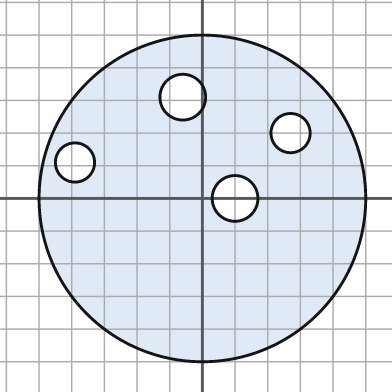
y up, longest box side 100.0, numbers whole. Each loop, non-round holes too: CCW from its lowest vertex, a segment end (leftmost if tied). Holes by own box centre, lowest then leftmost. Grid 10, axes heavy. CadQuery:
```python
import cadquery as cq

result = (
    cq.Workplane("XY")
    .moveTo(0.0, 0.0)
    .circle(50.0)
    .moveTo(10.0, 0.0)
    .circle(7.0)
    .moveTo(-39.0, 11.0)
    .circle(6.0)
    .moveTo(27.0, 20.0)
    .circle(6.0)
    .moveTo(-6.0, 31.0)
    .circle(7.0)
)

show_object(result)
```